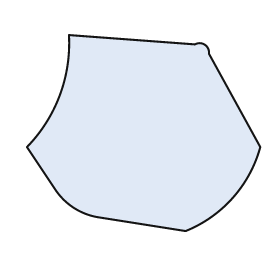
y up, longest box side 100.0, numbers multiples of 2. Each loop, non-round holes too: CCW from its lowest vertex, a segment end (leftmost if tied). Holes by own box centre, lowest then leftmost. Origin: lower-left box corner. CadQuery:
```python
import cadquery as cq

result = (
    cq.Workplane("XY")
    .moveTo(68.0, 0.0)
    .threePointArc((88.0, 14.0), (100.0, 36.0))
    .lineTo(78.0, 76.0)
    .threePointArc((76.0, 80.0), (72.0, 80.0))
    .lineTo(18.0, 84.0)
    .threePointArc((14.0, 58.0), (0.0, 36.0))
    .lineTo(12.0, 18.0)
    .threePointArc((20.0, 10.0), (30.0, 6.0))
    .close()
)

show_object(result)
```